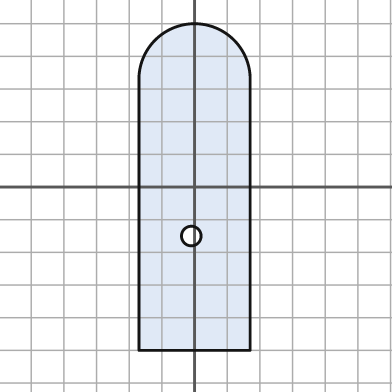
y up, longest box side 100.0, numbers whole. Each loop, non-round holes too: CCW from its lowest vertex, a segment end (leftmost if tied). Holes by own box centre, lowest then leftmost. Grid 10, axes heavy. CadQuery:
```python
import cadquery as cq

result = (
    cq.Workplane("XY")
    .moveTo(-17.0, -50.0)
    .lineTo(17.0, -50.0)
    .lineTo(17.0, 34.0)
    .threePointArc((0.0, 50.0), (-17.0, 34.0))
    .close()
    .moveTo(-1.0, -15.0)
    .circle(3.0)
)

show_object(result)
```